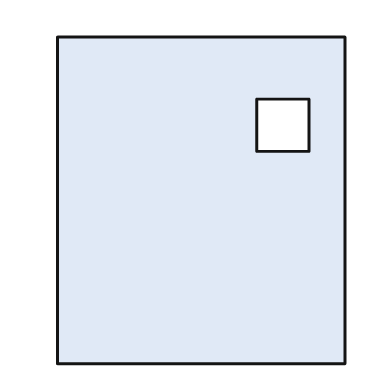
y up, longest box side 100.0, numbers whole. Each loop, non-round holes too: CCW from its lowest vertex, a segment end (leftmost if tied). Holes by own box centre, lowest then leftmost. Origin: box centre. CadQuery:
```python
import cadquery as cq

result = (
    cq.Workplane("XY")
    .moveTo(-44.0, -50.0)
    .lineTo(44.0, -50.0)
    .lineTo(44.0, 50.0)
    .lineTo(-44.0, 50.0)
    .close()
    .moveTo(17.0, 15.0)
    .lineTo(33.0, 15.0)
    .lineTo(33.0, 31.0)
    .lineTo(17.0, 31.0)
    .close()
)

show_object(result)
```